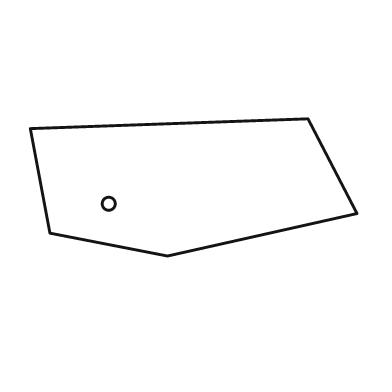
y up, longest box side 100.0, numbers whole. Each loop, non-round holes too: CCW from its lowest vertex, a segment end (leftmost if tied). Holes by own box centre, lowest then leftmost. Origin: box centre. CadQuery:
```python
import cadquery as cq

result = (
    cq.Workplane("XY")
    .moveTo(-8.0, -21.0)
    .lineTo(50.0, -8.0)
    .lineTo(35.0, 21.0)
    .lineTo(-50.0, 18.0)
    .lineTo(-44.0, -14.0)
    .close()
    .moveTo(-26.0, -5.0)
    .circle(2.0)
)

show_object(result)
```